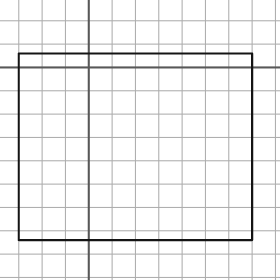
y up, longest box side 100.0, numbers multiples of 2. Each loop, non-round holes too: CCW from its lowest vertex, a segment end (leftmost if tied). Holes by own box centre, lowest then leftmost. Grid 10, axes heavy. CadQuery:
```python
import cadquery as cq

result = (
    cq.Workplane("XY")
    .moveTo(-30.0, -74.0)
    .lineTo(70.0, -74.0)
    .lineTo(70.0, 6.0)
    .lineTo(-30.0, 6.0)
    .close()
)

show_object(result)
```